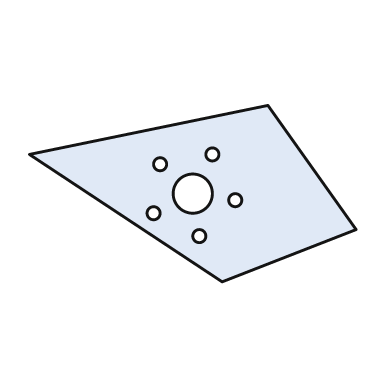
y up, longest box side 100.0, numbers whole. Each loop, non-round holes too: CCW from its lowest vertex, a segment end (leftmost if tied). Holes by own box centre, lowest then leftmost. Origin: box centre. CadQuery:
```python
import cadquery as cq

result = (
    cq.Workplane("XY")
    .moveTo(9.0, -27.0)
    .lineTo(50.0, -11.0)
    .lineTo(23.0, 27.0)
    .lineTo(-50.0, 12.0)
    .close()
    .moveTo(2.0, -13.0)
    .circle(2.0)
    .moveTo(-12.0, -6.0)
    .circle(2.0)
    .moveTo(13.0, -2.0)
    .circle(2.0)
    .moveTo(0.0, 0.0)
    .circle(6.0)
    .moveTo(-10.0, 9.0)
    .circle(2.0)
    .moveTo(6.0, 12.0)
    .circle(2.0)
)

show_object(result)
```